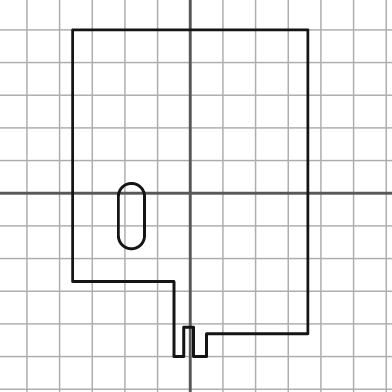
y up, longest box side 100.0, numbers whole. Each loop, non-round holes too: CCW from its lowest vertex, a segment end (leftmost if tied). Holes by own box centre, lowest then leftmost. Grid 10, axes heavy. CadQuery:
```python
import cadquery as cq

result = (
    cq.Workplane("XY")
    .moveTo(-5.0, -50.0)
    .lineTo(-2.0, -50.0)
    .lineTo(-2.0, -41.0)
    .lineTo(1.0, -41.0)
    .lineTo(1.0, -50.0)
    .lineTo(5.0, -50.0)
    .lineTo(5.0, -43.0)
    .lineTo(36.0, -43.0)
    .lineTo(36.0, 50.0)
    .lineTo(-36.0, 50.0)
    .lineTo(-36.0, -27.0)
    .lineTo(-5.0, -27.0)
    .close()
    .moveTo(-22.0, -13.0)
    .threePointArc((-18.0, -17.0), (-14.0, -13.0))
    .lineTo(-14.0, -1.0)
    .threePointArc((-18.0, 3.0), (-22.0, -1.0))
    .close()
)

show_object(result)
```